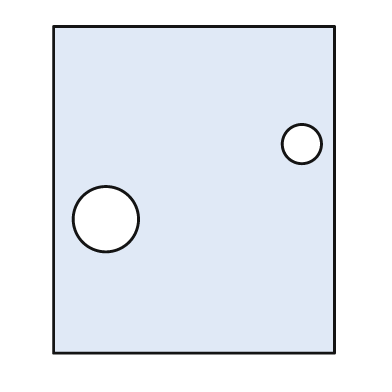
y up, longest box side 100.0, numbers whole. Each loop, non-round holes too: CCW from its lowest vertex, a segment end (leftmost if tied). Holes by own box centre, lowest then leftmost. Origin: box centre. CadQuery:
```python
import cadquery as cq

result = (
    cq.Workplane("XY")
    .moveTo(-43.0, -50.0)
    .lineTo(43.0, -50.0)
    .lineTo(43.0, 50.0)
    .lineTo(-43.0, 50.0)
    .close()
    .moveTo(-27.0, -9.0)
    .circle(10.0)
    .moveTo(33.0, 14.0)
    .circle(6.0)
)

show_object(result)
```